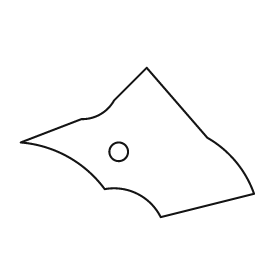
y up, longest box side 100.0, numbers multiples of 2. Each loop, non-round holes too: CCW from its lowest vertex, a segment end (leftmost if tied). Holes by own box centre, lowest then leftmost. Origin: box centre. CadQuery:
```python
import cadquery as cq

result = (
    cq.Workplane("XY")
    .moveTo(10.0, -32.0)
    .lineTo(50.0, -22.0)
    .threePointArc((42.0, -8.0), (30.0, 2.0))
    .lineTo(4.0, 32.0)
    .lineTo(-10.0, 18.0)
    .threePointArc((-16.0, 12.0), (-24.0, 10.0))
    .lineTo(-50.0, 0.0)
    .threePointArc((-30.0, -6.0), (-14.0, -20.0))
    .threePointArc((0.0, -22.0), (10.0, -32.0))
    .close()
    .moveTo(-8.0, -4.0)
    .circle(4.0)
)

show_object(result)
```